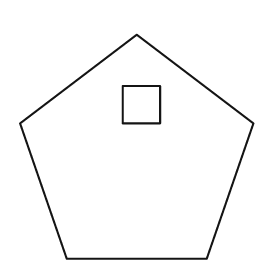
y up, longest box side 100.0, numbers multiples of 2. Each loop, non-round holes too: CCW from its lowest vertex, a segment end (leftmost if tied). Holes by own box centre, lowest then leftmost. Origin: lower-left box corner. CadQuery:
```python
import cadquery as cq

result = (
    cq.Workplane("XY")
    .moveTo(20.0, 0.0)
    .lineTo(80.0, 0.0)
    .lineTo(100.0, 58.0)
    .lineTo(50.0, 96.0)
    .lineTo(0.0, 58.0)
    .close()
    .moveTo(44.0, 58.0)
    .lineTo(60.0, 58.0)
    .lineTo(60.0, 74.0)
    .lineTo(44.0, 74.0)
    .close()
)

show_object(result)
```